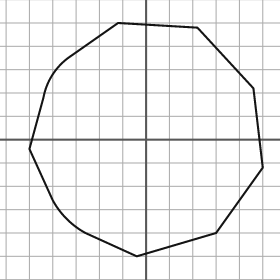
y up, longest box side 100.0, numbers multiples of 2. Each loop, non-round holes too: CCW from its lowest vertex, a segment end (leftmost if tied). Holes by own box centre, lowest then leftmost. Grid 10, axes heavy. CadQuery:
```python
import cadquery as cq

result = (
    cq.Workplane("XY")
    .moveTo(-4.0, -50.0)
    .lineTo(30.0, -40.0)
    .lineTo(50.0, -12.0)
    .lineTo(46.0, 22.0)
    .lineTo(22.0, 48.0)
    .lineTo(-12.0, 50.0)
    .lineTo(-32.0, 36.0)
    .threePointArc((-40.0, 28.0), (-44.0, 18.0))
    .lineTo(-50.0, -4.0)
    .lineTo(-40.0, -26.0)
    .threePointArc((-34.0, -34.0), (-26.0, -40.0))
    .close()
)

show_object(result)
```